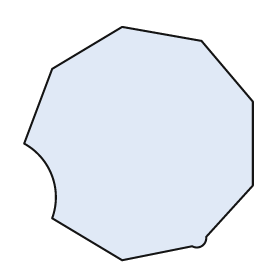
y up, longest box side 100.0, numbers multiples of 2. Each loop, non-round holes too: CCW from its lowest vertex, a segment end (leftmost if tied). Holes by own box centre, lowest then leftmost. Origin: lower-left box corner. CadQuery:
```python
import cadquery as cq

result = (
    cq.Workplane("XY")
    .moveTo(42.0, 0.0)
    .lineTo(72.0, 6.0)
    .threePointArc((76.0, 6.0), (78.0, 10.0))
    .lineTo(98.0, 32.0)
    .lineTo(98.0, 68.0)
    .lineTo(76.0, 94.0)
    .lineTo(42.0, 100.0)
    .lineTo(12.0, 82.0)
    .lineTo(0.0, 50.0)
    .threePointArc((12.0, 36.0), (12.0, 18.0))
    .close()
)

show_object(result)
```